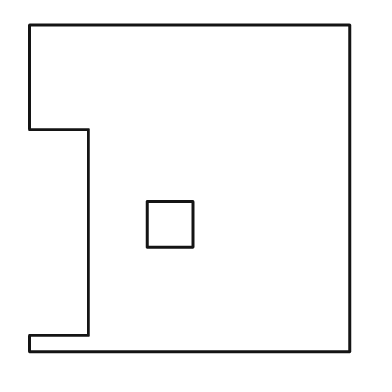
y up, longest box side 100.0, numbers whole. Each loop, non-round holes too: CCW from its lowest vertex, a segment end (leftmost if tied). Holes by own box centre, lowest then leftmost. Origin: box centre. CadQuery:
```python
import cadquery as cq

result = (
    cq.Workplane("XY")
    .moveTo(-49.0, -50.0)
    .lineTo(49.0, -50.0)
    .lineTo(49.0, 50.0)
    .lineTo(-49.0, 50.0)
    .lineTo(-49.0, 18.0)
    .lineTo(-31.0, 18.0)
    .lineTo(-31.0, -45.0)
    .lineTo(-49.0, -45.0)
    .close()
    .moveTo(-13.0, -18.0)
    .lineTo(1.0, -18.0)
    .lineTo(1.0, -4.0)
    .lineTo(-13.0, -4.0)
    .close()
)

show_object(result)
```